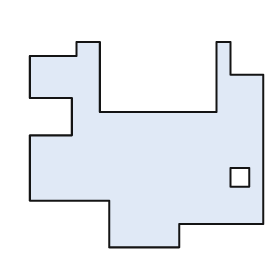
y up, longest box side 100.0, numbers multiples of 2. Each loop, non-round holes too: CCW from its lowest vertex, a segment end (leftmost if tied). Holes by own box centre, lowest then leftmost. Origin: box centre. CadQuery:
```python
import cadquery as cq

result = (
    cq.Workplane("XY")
    .moveTo(-16.0, -44.0)
    .lineTo(14.0, -44.0)
    .lineTo(14.0, -34.0)
    .lineTo(50.0, -34.0)
    .lineTo(50.0, 30.0)
    .lineTo(36.0, 30.0)
    .lineTo(36.0, 44.0)
    .lineTo(30.0, 44.0)
    .lineTo(30.0, 14.0)
    .lineTo(-20.0, 14.0)
    .lineTo(-20.0, 44.0)
    .lineTo(-30.0, 44.0)
    .lineTo(-30.0, 38.0)
    .lineTo(-50.0, 38.0)
    .lineTo(-50.0, 20.0)
    .lineTo(-32.0, 20.0)
    .lineTo(-32.0, 4.0)
    .lineTo(-50.0, 4.0)
    .lineTo(-50.0, -24.0)
    .lineTo(-16.0, -24.0)
    .close()
    .moveTo(36.0, -18.0)
    .lineTo(44.0, -18.0)
    .lineTo(44.0, -10.0)
    .lineTo(36.0, -10.0)
    .close()
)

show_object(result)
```